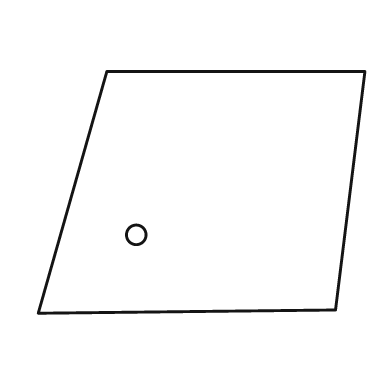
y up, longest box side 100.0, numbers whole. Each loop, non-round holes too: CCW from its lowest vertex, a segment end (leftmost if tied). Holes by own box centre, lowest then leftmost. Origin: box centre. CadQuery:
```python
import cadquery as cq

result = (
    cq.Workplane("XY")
    .moveTo(-50.0, -37.0)
    .lineTo(41.0, -36.0)
    .lineTo(50.0, 37.0)
    .lineTo(-29.0, 37.0)
    .close()
    .moveTo(-20.0, -13.0)
    .circle(3.0)
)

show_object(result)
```